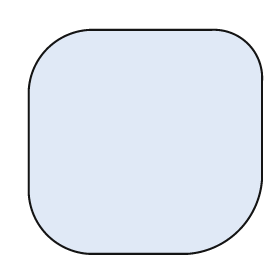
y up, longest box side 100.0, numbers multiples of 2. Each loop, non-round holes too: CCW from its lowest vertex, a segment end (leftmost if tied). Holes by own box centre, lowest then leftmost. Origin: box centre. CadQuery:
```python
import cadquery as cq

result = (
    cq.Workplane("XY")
    .moveTo(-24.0, -48.0)
    .lineTo(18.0, -48.0)
    .threePointArc((40.0, -38.0), (50.0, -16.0))
    .lineTo(50.0, 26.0)
    .threePointArc((44.0, 42.0), (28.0, 48.0))
    .lineTo(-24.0, 48.0)
    .threePointArc((-42.0, 40.0), (-50.0, 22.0))
    .lineTo(-50.0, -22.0)
    .threePointArc((-42.0, -40.0), (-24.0, -48.0))
    .close()
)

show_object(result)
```